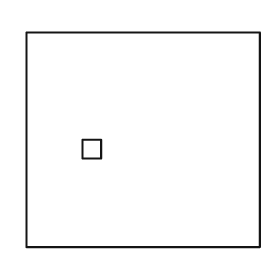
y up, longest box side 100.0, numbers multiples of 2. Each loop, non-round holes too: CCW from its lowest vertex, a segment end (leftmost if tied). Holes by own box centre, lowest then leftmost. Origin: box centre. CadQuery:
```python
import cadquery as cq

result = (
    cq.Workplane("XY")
    .moveTo(-50.0, -46.0)
    .lineTo(50.0, -46.0)
    .lineTo(50.0, 46.0)
    .lineTo(-50.0, 46.0)
    .close()
    .moveTo(-26.0, -8.0)
    .lineTo(-18.0, -8.0)
    .lineTo(-18.0, 0.0)
    .lineTo(-26.0, 0.0)
    .close()
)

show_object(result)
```